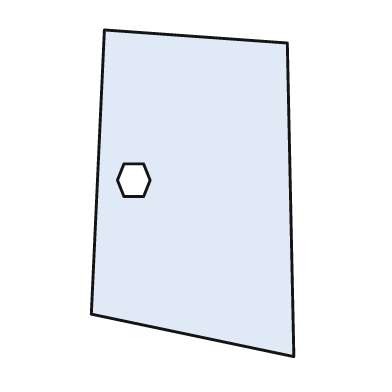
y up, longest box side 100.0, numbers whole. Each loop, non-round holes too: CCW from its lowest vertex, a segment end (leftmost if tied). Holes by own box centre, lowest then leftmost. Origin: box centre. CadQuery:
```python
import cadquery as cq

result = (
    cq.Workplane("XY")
    .moveTo(31.0, -50.0)
    .lineTo(29.0, 46.0)
    .lineTo(-27.0, 50.0)
    .lineTo(-31.0, -37.0)
    .close()
    .moveTo(-21.0, -1.0)
    .lineTo(-15.0, -1.0)
    .lineTo(-13.0, 4.0)
    .lineTo(-15.0, 9.0)
    .lineTo(-21.0, 9.0)
    .lineTo(-23.0, 4.0)
    .close()
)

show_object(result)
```